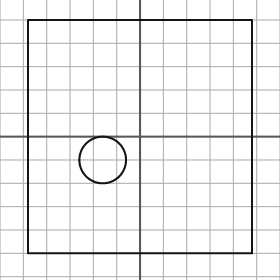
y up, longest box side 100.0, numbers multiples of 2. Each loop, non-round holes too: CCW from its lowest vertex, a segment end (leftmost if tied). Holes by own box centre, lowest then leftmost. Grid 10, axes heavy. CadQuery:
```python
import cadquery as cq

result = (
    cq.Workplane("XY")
    .moveTo(-48.0, -50.0)
    .lineTo(48.0, -50.0)
    .lineTo(48.0, 50.0)
    .lineTo(-48.0, 50.0)
    .close()
    .moveTo(-16.0, -10.0)
    .circle(10.0)
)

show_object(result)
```